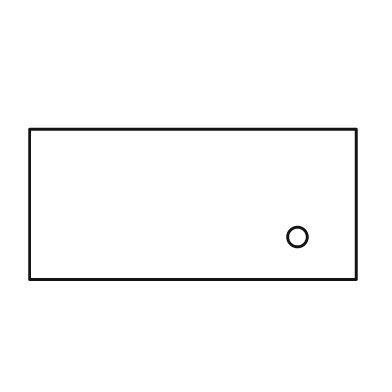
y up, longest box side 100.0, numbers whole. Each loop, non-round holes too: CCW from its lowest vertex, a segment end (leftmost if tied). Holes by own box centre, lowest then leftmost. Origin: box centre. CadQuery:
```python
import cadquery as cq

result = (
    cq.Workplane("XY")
    .moveTo(-50.0, -23.0)
    .lineTo(50.0, -23.0)
    .lineTo(50.0, 23.0)
    .lineTo(-50.0, 23.0)
    .close()
    .moveTo(32.0, -10.0)
    .circle(3.0)
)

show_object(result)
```